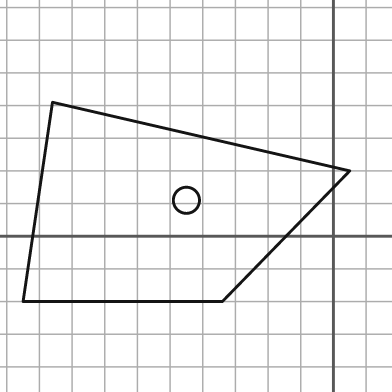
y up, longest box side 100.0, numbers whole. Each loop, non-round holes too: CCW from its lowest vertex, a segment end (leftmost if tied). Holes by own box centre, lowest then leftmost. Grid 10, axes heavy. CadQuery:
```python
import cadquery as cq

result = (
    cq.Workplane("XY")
    .moveTo(-95.0, -20.0)
    .lineTo(-34.0, -20.0)
    .lineTo(5.0, 20.0)
    .lineTo(-86.0, 41.0)
    .close()
    .moveTo(-45.0, 11.0)
    .circle(4.0)
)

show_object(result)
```